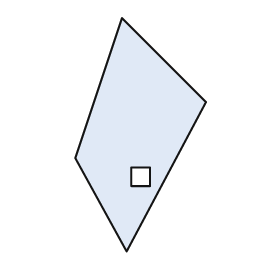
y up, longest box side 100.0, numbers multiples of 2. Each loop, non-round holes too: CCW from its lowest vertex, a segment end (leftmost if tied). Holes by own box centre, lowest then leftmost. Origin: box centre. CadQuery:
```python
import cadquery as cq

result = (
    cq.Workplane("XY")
    .moveTo(-6.0, -50.0)
    .lineTo(28.0, 14.0)
    .lineTo(-8.0, 50.0)
    .lineTo(-28.0, -10.0)
    .close()
    .moveTo(-4.0, -22.0)
    .lineTo(4.0, -22.0)
    .lineTo(4.0, -14.0)
    .lineTo(-4.0, -14.0)
    .close()
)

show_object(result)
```